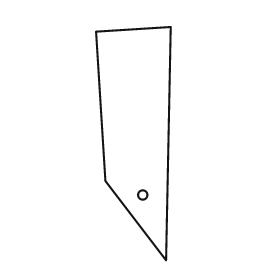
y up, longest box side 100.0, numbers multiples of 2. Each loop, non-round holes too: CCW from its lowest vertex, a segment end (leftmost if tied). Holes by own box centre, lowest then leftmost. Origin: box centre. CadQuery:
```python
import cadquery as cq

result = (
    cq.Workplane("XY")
    .moveTo(14.0, -50.0)
    .lineTo(16.0, 50.0)
    .lineTo(-16.0, 48.0)
    .lineTo(-12.0, -16.0)
    .close()
    .moveTo(4.0, -22.0)
    .circle(2.0)
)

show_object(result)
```